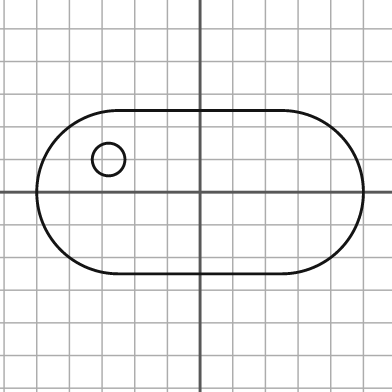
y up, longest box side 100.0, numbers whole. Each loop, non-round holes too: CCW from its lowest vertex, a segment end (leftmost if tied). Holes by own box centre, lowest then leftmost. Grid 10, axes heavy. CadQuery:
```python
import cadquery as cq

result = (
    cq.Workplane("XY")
    .moveTo(-25.0, -25.0)
    .lineTo(25.0, -25.0)
    .threePointArc((50.0, 0.0), (25.0, 25.0))
    .lineTo(-25.0, 25.0)
    .threePointArc((-50.0, 0.0), (-25.0, -25.0))
    .close()
    .moveTo(-28.0, 10.0)
    .circle(5.0)
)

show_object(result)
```